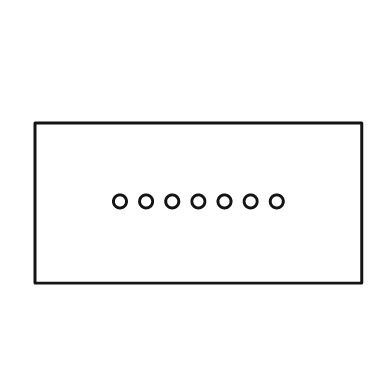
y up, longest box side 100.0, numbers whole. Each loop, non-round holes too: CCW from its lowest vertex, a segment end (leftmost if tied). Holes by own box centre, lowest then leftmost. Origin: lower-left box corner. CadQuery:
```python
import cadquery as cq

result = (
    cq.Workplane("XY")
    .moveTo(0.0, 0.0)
    .lineTo(100.0, 0.0)
    .lineTo(100.0, 49.0)
    .lineTo(0.0, 49.0)
    .close()
    .moveTo(26.0, 25.0)
    .circle(2.0)
    .moveTo(34.0, 25.0)
    .circle(2.0)
    .moveTo(42.0, 25.0)
    .circle(2.0)
    .moveTo(50.0, 25.0)
    .circle(2.0)
    .moveTo(58.0, 25.0)
    .circle(2.0)
    .moveTo(66.0, 25.0)
    .circle(2.0)
    .moveTo(74.0, 25.0)
    .circle(2.0)
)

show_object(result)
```